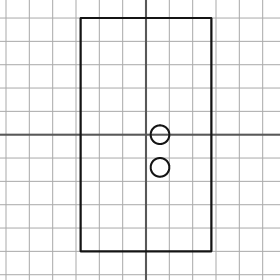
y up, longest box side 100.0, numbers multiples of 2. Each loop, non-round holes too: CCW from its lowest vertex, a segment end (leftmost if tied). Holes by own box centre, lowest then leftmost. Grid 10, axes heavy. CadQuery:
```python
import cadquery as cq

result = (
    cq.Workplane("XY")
    .moveTo(-28.0, -50.0)
    .lineTo(28.0, -50.0)
    .lineTo(28.0, 50.0)
    .lineTo(-28.0, 50.0)
    .close()
    .moveTo(6.0, -14.0)
    .circle(4.0)
    .moveTo(6.0, 0.0)
    .circle(4.0)
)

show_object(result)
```